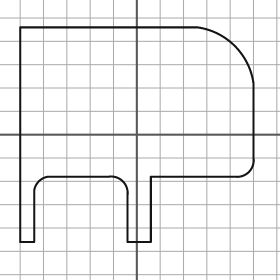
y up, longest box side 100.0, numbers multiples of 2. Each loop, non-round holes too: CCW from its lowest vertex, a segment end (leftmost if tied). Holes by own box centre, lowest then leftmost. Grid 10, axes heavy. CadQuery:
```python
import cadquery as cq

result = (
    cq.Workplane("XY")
    .moveTo(-50.0, -46.0)
    .lineTo(-44.0, -46.0)
    .lineTo(-44.0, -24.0)
    .threePointArc((-42.0, -20.0), (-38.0, -18.0))
    .lineTo(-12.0, -18.0)
    .threePointArc((-6.0, -20.0), (-4.0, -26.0))
    .lineTo(-4.0, -46.0)
    .lineTo(6.0, -46.0)
    .lineTo(6.0, -18.0)
    .lineTo(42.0, -18.0)
    .threePointArc((48.0, -16.0), (50.0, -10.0))
    .lineTo(50.0, 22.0)
    .threePointArc((42.0, 38.0), (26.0, 46.0))
    .lineTo(-50.0, 46.0)
    .close()
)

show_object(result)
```